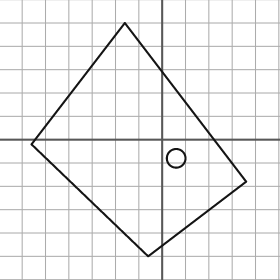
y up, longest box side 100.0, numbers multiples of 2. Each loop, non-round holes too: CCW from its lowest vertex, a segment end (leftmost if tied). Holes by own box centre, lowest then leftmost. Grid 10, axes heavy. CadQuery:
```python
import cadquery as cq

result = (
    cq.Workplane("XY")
    .moveTo(-6.0, -50.0)
    .lineTo(36.0, -18.0)
    .lineTo(-16.0, 50.0)
    .lineTo(-56.0, -2.0)
    .close()
    .moveTo(6.0, -8.0)
    .circle(4.0)
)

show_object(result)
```